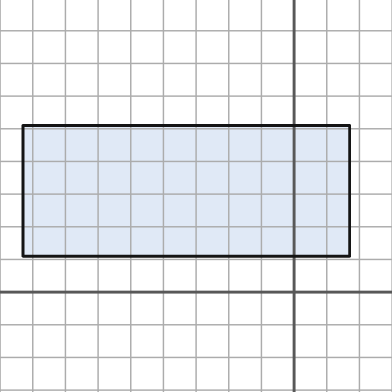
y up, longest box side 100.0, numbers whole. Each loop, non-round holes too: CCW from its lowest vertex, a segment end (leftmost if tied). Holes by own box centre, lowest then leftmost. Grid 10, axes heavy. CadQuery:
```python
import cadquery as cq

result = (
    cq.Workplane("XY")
    .moveTo(-83.0, 11.0)
    .lineTo(17.0, 11.0)
    .lineTo(17.0, 51.0)
    .lineTo(-83.0, 51.0)
    .close()
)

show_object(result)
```